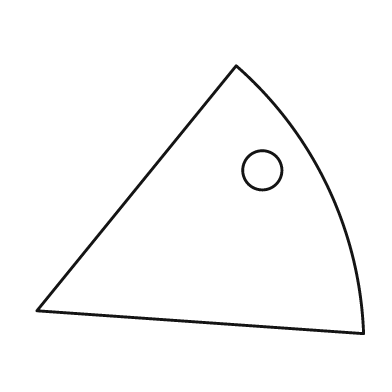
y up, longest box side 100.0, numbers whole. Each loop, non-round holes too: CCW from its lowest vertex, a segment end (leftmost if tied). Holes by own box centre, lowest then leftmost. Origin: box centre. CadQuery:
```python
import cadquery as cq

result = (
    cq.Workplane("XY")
    .moveTo(50.0, -41.0)
    .threePointArc((39.0, 4.0), (11.0, 41.0))
    .lineTo(-50.0, -34.0)
    .close()
    .moveTo(19.0, 9.0)
    .circle(6.0)
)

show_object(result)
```